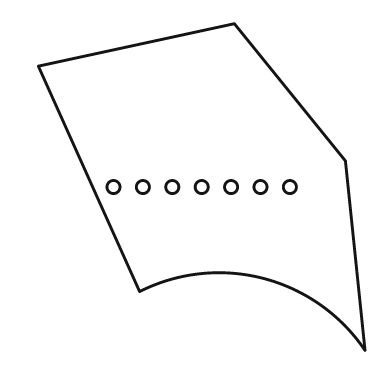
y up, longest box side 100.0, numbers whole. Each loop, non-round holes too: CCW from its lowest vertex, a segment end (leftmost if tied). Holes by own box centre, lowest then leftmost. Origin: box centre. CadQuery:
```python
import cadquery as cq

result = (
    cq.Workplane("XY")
    .moveTo(50.0, -50.0)
    .lineTo(44.0, 8.0)
    .lineTo(10.0, 50.0)
    .lineTo(-50.0, 37.0)
    .lineTo(-19.0, -32.0)
    .threePointArc((19.0, -28.0), (50.0, -50.0))
    .close()
    .moveTo(-27.0, 0.0)
    .circle(2.0)
    .moveTo(-18.0, 0.0)
    .circle(2.0)
    .moveTo(-9.0, 0.0)
    .circle(2.0)
    .moveTo(0.0, 0.0)
    .circle(2.0)
    .moveTo(9.0, 0.0)
    .circle(2.0)
    .moveTo(18.0, 0.0)
    .circle(2.0)
    .moveTo(27.0, 0.0)
    .circle(2.0)
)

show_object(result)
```